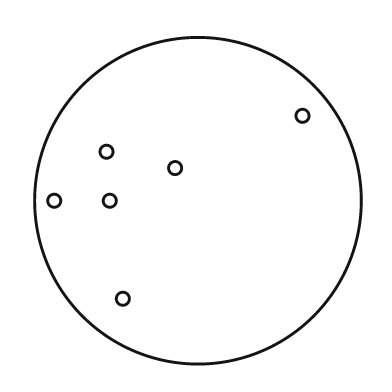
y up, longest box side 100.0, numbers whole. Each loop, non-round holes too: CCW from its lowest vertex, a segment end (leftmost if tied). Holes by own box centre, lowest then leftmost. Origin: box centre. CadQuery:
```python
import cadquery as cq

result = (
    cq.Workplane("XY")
    .moveTo(0.0, 0.0)
    .circle(50.0)
    .moveTo(-23.0, -30.0)
    .circle(2.0)
    .moveTo(-44.0, 0.0)
    .circle(2.0)
    .moveTo(-27.0, 0.0)
    .circle(2.0)
    .moveTo(-7.0, 10.0)
    .circle(2.0)
    .moveTo(-28.0, 15.0)
    .circle(2.0)
    .moveTo(32.0, 26.0)
    .circle(2.0)
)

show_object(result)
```